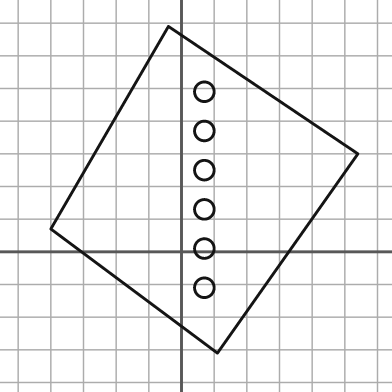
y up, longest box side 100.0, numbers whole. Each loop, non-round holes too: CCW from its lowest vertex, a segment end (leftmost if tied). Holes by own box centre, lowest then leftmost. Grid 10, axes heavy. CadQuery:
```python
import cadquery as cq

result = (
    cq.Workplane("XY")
    .moveTo(11.0, -31.0)
    .lineTo(54.0, 30.0)
    .lineTo(-4.0, 69.0)
    .lineTo(-40.0, 7.0)
    .close()
    .moveTo(7.0, -11.0)
    .circle(3.0)
    .moveTo(7.0, 1.0)
    .circle(3.0)
    .moveTo(7.0, 13.0)
    .circle(3.0)
    .moveTo(7.0, 25.0)
    .circle(3.0)
    .moveTo(7.0, 37.0)
    .circle(3.0)
    .moveTo(7.0, 49.0)
    .circle(3.0)
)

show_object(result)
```